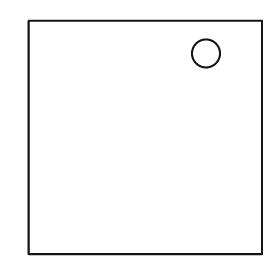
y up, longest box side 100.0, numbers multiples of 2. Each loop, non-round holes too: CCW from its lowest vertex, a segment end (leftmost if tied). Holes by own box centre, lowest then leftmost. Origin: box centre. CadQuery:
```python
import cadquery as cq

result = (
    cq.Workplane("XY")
    .moveTo(-50.0, -50.0)
    .lineTo(50.0, -50.0)
    .lineTo(50.0, 50.0)
    .lineTo(-50.0, 50.0)
    .close()
    .moveTo(26.0, 36.0)
    .circle(6.0)
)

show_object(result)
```